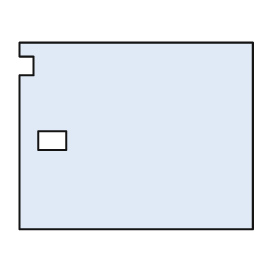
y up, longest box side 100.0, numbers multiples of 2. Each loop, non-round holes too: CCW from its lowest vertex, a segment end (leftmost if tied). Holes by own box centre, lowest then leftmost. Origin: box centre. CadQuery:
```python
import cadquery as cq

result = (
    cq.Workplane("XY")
    .moveTo(-50.0, -40.0)
    .lineTo(50.0, -40.0)
    .lineTo(50.0, 40.0)
    .lineTo(-50.0, 40.0)
    .lineTo(-50.0, 34.0)
    .lineTo(-44.0, 34.0)
    .lineTo(-44.0, 26.0)
    .lineTo(-50.0, 26.0)
    .close()
    .moveTo(-42.0, -6.0)
    .lineTo(-30.0, -6.0)
    .lineTo(-30.0, 2.0)
    .lineTo(-42.0, 2.0)
    .close()
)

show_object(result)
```